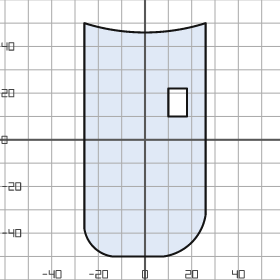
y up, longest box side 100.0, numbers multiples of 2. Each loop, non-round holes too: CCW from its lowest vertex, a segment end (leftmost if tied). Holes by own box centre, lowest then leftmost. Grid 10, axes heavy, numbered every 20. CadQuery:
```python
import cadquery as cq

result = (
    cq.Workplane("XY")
    .moveTo(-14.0, -50.0)
    .lineTo(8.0, -50.0)
    .threePointArc((20.0, -44.0), (26.0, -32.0))
    .lineTo(26.0, 50.0)
    .threePointArc((0.0, 46.0), (-26.0, 50.0))
    .lineTo(-26.0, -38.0)
    .threePointArc((-22.0, -46.0), (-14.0, -50.0))
    .close()
    .moveTo(10.0, 10.0)
    .lineTo(18.0, 10.0)
    .lineTo(18.0, 22.0)
    .lineTo(10.0, 22.0)
    .close()
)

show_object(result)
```